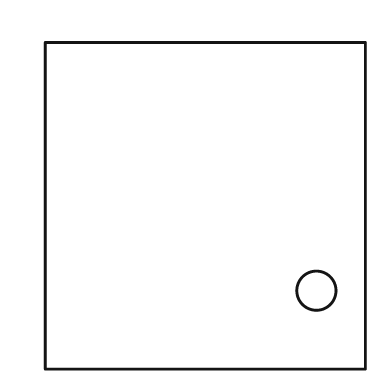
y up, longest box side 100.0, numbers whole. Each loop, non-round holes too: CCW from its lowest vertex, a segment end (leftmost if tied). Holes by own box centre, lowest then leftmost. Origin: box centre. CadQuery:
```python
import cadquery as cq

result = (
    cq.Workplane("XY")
    .moveTo(-49.0, -50.0)
    .lineTo(49.0, -50.0)
    .lineTo(49.0, 50.0)
    .lineTo(-49.0, 50.0)
    .close()
    .moveTo(34.0, -26.0)
    .circle(6.0)
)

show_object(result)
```